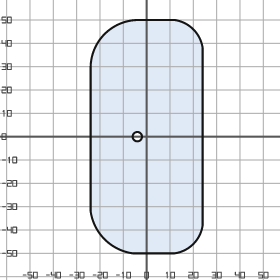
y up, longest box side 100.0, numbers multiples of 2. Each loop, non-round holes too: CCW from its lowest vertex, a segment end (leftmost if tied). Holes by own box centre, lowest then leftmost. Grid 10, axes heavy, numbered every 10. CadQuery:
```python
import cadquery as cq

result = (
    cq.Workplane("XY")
    .moveTo(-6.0, -50.0)
    .lineTo(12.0, -50.0)
    .threePointArc((20.0, -46.0), (24.0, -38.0))
    .lineTo(24.0, 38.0)
    .threePointArc((20.0, 46.0), (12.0, 50.0))
    .lineTo(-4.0, 50.0)
    .threePointArc((-18.0, 44.0), (-24.0, 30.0))
    .lineTo(-24.0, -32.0)
    .threePointArc((-18.0, -44.0), (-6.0, -50.0))
    .close()
    .moveTo(-4.0, 0.0)
    .circle(2.0)
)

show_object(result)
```